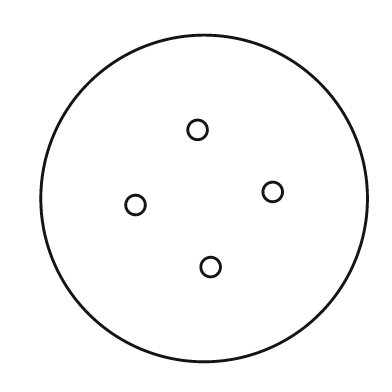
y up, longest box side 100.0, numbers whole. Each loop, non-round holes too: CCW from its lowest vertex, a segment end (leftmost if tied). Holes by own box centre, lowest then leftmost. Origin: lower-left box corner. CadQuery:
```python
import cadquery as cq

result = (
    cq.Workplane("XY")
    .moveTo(50.0, 50.0)
    .circle(50.0)
    .moveTo(52.0, 29.0)
    .circle(3.0)
    .moveTo(29.0, 48.0)
    .circle(3.0)
    .moveTo(71.0, 52.0)
    .circle(3.0)
    .moveTo(48.0, 71.0)
    .circle(3.0)
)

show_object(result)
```